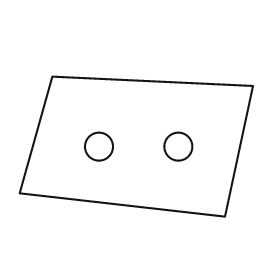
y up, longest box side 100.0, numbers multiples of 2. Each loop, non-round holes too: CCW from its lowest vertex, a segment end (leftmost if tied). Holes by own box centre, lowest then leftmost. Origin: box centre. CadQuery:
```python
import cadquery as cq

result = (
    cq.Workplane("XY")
    .moveTo(38.0, -30.0)
    .lineTo(50.0, 26.0)
    .lineTo(-36.0, 30.0)
    .lineTo(-50.0, -20.0)
    .close()
    .moveTo(-16.0, 0.0)
    .circle(6.0)
    .moveTo(18.0, 0.0)
    .circle(6.0)
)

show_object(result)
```